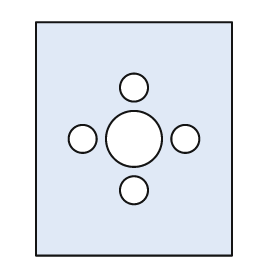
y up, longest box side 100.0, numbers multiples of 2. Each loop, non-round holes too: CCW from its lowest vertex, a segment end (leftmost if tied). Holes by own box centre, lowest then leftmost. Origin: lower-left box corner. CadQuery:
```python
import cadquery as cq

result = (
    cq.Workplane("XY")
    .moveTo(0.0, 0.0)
    .lineTo(84.0, 0.0)
    .lineTo(84.0, 100.0)
    .lineTo(0.0, 100.0)
    .close()
    .moveTo(42.0, 28.0)
    .circle(6.0)
    .moveTo(20.0, 50.0)
    .circle(6.0)
    .moveTo(42.0, 50.0)
    .circle(12.0)
    .moveTo(64.0, 50.0)
    .circle(6.0)
    .moveTo(42.0, 72.0)
    .circle(6.0)
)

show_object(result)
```